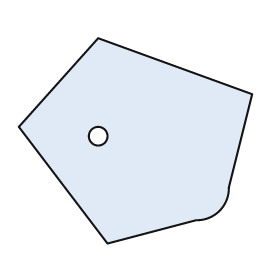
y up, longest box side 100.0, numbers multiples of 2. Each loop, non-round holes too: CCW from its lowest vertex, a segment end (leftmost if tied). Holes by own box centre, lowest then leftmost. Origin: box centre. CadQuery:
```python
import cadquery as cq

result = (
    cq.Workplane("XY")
    .moveTo(-12.0, -44.0)
    .lineTo(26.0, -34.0)
    .threePointArc((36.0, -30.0), (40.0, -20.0))
    .lineTo(50.0, 20.0)
    .lineTo(-16.0, 44.0)
    .lineTo(-50.0, 6.0)
    .close()
    .moveTo(-16.0, 2.0)
    .circle(4.0)
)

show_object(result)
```